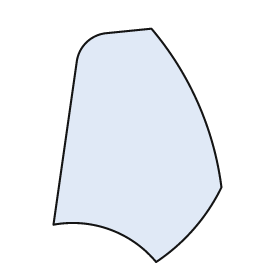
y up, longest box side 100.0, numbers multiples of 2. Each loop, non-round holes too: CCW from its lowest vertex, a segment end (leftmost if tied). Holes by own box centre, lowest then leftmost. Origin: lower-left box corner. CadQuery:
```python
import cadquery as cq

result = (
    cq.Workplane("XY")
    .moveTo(44.0, 0.0)
    .threePointArc((60.0, 14.0), (72.0, 32.0))
    .threePointArc((62.0, 68.0), (42.0, 100.0))
    .lineTo(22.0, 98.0)
    .threePointArc((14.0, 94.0), (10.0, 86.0))
    .lineTo(0.0, 16.0)
    .threePointArc((24.0, 14.0), (44.0, 0.0))
    .close()
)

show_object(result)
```